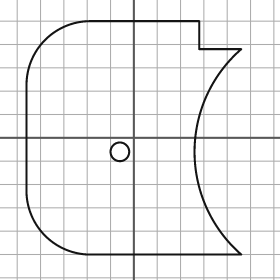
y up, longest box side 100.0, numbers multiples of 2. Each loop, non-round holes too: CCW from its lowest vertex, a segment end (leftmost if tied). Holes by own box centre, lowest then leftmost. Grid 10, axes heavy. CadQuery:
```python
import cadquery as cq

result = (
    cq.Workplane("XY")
    .moveTo(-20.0, -50.0)
    .lineTo(46.0, -50.0)
    .threePointArc((26.0, -6.0), (46.0, 38.0))
    .lineTo(28.0, 38.0)
    .lineTo(28.0, 50.0)
    .lineTo(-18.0, 50.0)
    .threePointArc((-38.0, 42.0), (-46.0, 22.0))
    .lineTo(-46.0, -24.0)
    .threePointArc((-38.0, -42.0), (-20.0, -50.0))
    .close()
    .moveTo(-6.0, -6.0)
    .circle(4.0)
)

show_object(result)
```